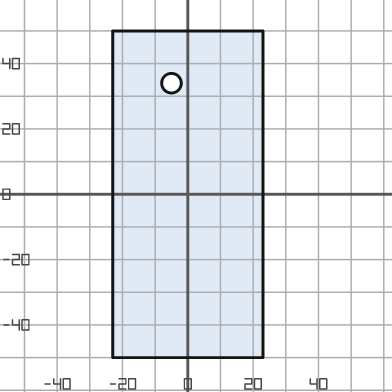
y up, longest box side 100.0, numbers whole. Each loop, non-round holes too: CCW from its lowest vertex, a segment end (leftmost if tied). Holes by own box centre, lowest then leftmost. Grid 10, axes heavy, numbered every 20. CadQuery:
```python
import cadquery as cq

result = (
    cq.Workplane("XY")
    .moveTo(-23.0, -50.0)
    .lineTo(23.0, -50.0)
    .lineTo(23.0, 50.0)
    .lineTo(-23.0, 50.0)
    .close()
    .moveTo(-5.0, 34.0)
    .circle(3.0)
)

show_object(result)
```